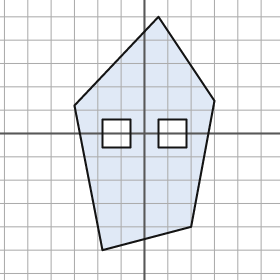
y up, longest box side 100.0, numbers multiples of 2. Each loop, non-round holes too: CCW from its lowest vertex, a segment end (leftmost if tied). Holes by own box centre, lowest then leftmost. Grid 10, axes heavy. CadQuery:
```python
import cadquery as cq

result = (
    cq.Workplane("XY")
    .moveTo(-18.0, -50.0)
    .lineTo(20.0, -40.0)
    .lineTo(30.0, 14.0)
    .lineTo(6.0, 50.0)
    .lineTo(-30.0, 12.0)
    .close()
    .moveTo(-18.0, -6.0)
    .lineTo(-6.0, -6.0)
    .lineTo(-6.0, 6.0)
    .lineTo(-18.0, 6.0)
    .close()
    .moveTo(6.0, -6.0)
    .lineTo(18.0, -6.0)
    .lineTo(18.0, 6.0)
    .lineTo(6.0, 6.0)
    .close()
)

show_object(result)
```